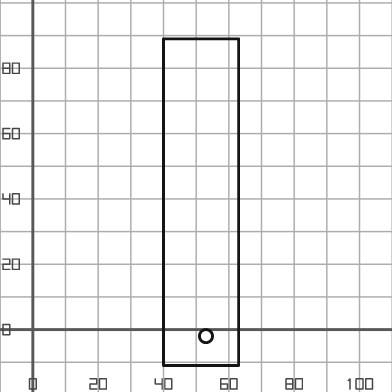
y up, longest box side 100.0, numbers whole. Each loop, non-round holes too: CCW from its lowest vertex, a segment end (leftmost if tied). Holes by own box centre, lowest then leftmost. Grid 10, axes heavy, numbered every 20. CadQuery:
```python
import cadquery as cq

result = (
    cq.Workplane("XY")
    .moveTo(40.0, -11.0)
    .lineTo(63.0, -11.0)
    .lineTo(63.0, 89.0)
    .lineTo(40.0, 89.0)
    .close()
    .moveTo(53.0, -2.0)
    .circle(2.0)
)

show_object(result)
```